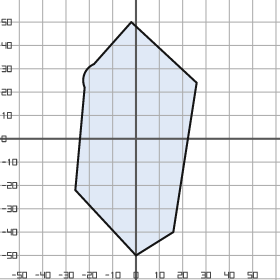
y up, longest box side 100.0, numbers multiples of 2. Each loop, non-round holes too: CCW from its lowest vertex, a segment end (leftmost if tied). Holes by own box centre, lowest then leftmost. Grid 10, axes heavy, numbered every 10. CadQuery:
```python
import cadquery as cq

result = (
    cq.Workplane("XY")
    .moveTo(0.0, -50.0)
    .lineTo(16.0, -40.0)
    .lineTo(26.0, 24.0)
    .lineTo(-2.0, 50.0)
    .lineTo(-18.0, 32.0)
    .threePointArc((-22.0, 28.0), (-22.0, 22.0))
    .lineTo(-26.0, -22.0)
    .close()
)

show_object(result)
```